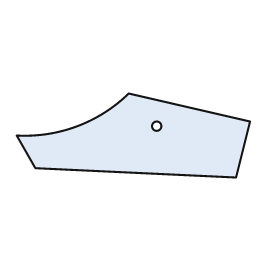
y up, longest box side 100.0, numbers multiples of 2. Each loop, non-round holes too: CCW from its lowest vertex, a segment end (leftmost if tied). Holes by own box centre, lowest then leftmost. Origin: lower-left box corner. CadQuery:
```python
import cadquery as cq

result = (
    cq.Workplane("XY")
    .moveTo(94.0, 0.0)
    .lineTo(100.0, 24.0)
    .lineTo(48.0, 36.0)
    .threePointArc((26.0, 22.0), (0.0, 18.0))
    .lineTo(8.0, 4.0)
    .close()
    .moveTo(60.0, 22.0)
    .circle(2.0)
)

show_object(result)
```